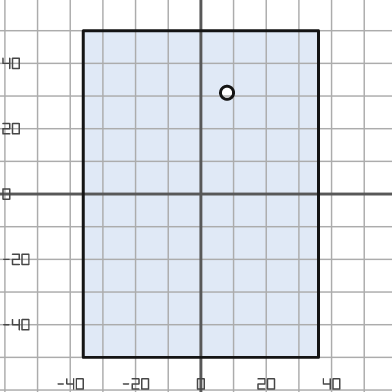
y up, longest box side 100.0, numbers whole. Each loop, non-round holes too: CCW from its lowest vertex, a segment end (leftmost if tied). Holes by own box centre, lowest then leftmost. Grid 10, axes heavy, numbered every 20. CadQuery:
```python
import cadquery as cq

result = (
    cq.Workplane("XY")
    .moveTo(-36.0, -50.0)
    .lineTo(36.0, -50.0)
    .lineTo(36.0, 50.0)
    .lineTo(-36.0, 50.0)
    .close()
    .moveTo(8.0, 31.0)
    .circle(2.0)
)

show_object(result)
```